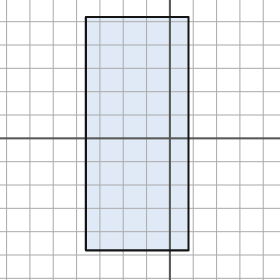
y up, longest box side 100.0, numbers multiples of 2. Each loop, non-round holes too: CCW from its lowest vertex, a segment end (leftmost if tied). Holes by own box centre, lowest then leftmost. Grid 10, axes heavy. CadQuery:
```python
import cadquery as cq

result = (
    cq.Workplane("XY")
    .moveTo(-36.0, -48.0)
    .lineTo(8.0, -48.0)
    .lineTo(8.0, 52.0)
    .lineTo(-36.0, 52.0)
    .close()
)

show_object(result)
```